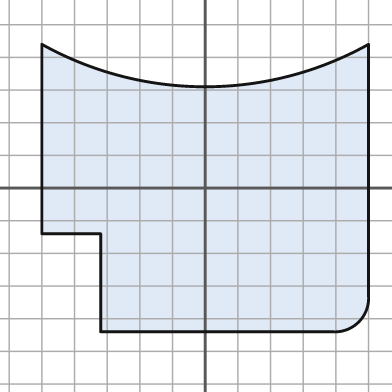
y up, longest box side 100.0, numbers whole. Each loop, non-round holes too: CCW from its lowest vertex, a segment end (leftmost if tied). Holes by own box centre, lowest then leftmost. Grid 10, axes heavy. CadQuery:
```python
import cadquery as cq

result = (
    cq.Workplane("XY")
    .moveTo(-32.0, -44.0)
    .lineTo(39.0, -44.0)
    .threePointArc((47.0, -41.0), (50.0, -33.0))
    .lineTo(50.0, 44.0)
    .threePointArc((0.0, 31.0), (-50.0, 44.0))
    .lineTo(-50.0, -14.0)
    .lineTo(-32.0, -14.0)
    .close()
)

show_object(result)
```